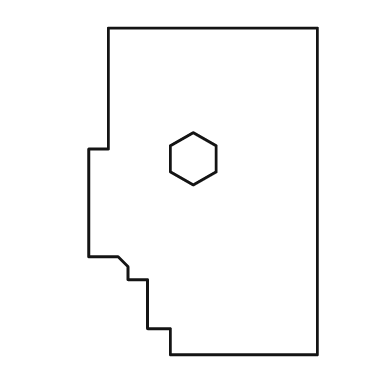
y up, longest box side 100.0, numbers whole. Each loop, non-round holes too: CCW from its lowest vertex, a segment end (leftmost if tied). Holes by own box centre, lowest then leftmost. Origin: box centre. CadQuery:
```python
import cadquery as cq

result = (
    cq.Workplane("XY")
    .moveTo(-10.0, -50.0)
    .lineTo(35.0, -50.0)
    .lineTo(35.0, 50.0)
    .lineTo(-29.0, 50.0)
    .lineTo(-29.0, 13.0)
    .lineTo(-35.0, 13.0)
    .lineTo(-35.0, -20.0)
    .lineTo(-26.0, -20.0)
    .lineTo(-23.0, -23.0)
    .lineTo(-23.0, -27.0)
    .lineTo(-17.0, -27.0)
    .lineTo(-17.0, -42.0)
    .lineTo(-10.0, -42.0)
    .close()
    .moveTo(-3.0, 2.0)
    .lineTo(4.0, 6.0)
    .lineTo(4.0, 14.0)
    .lineTo(-3.0, 18.0)
    .lineTo(-10.0, 14.0)
    .lineTo(-10.0, 6.0)
    .close()
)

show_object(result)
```